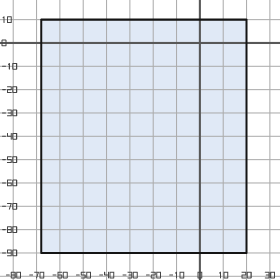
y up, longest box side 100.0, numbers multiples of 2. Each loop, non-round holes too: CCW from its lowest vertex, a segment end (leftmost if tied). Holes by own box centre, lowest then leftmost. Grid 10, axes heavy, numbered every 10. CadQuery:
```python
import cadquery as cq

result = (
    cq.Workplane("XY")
    .moveTo(-68.0, -90.0)
    .lineTo(20.0, -90.0)
    .lineTo(20.0, 10.0)
    .lineTo(-68.0, 10.0)
    .close()
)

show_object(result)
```